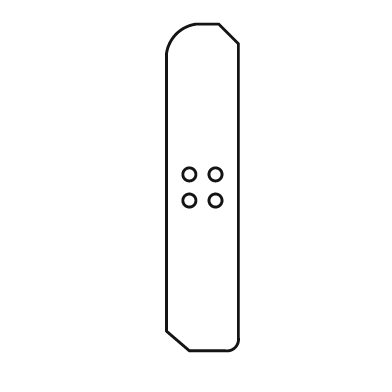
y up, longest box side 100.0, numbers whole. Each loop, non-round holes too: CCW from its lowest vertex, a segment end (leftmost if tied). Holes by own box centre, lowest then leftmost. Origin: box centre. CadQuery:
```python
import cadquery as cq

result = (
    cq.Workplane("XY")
    .moveTo(-4.0, -50.0)
    .lineTo(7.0, -50.0)
    .threePointArc((10.0, -49.0), (11.0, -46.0))
    .lineTo(11.0, 44.0)
    .lineTo(5.0, 50.0)
    .lineTo(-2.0, 50.0)
    .threePointArc((-8.0, 47.0), (-11.0, 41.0))
    .lineTo(-11.0, -44.0)
    .close()
    .moveTo(-4.0, -4.0)
    .circle(2.0)
    .moveTo(4.0, -4.0)
    .circle(2.0)
    .moveTo(-4.0, 4.0)
    .circle(2.0)
    .moveTo(4.0, 4.0)
    .circle(2.0)
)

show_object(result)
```